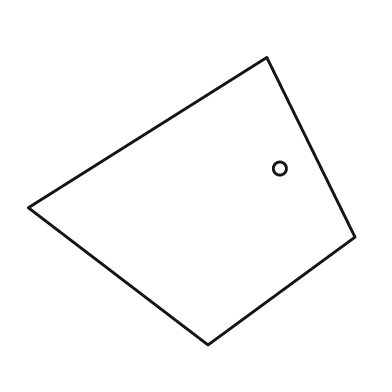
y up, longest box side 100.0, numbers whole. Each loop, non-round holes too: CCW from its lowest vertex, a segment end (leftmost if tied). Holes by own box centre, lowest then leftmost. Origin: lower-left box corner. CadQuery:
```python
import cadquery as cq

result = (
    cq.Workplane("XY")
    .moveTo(55.0, 0.0)
    .lineTo(100.0, 33.0)
    .lineTo(73.0, 88.0)
    .lineTo(0.0, 42.0)
    .close()
    .moveTo(77.0, 54.0)
    .circle(2.0)
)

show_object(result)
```